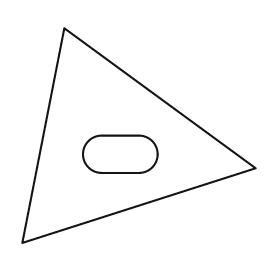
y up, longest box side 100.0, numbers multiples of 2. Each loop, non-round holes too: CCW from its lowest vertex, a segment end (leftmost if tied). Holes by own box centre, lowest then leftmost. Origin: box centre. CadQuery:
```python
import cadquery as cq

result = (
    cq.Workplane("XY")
    .moveTo(-50.0, -46.0)
    .lineTo(50.0, -14.0)
    .lineTo(-32.0, 46.0)
    .close()
    .moveTo(-16.0, -16.0)
    .lineTo(0.0, -16.0)
    .threePointArc((8.0, -8.0), (0.0, 0.0))
    .lineTo(-16.0, 0.0)
    .threePointArc((-24.0, -8.0), (-16.0, -16.0))
    .close()
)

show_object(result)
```